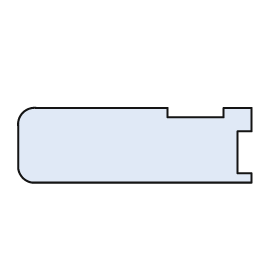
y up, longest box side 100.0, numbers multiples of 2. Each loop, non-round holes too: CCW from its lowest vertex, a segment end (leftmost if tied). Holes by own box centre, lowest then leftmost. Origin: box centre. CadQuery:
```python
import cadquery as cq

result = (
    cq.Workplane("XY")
    .moveTo(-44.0, -16.0)
    .lineTo(50.0, -16.0)
    .lineTo(50.0, -12.0)
    .lineTo(44.0, -12.0)
    .lineTo(44.0, 6.0)
    .lineTo(50.0, 6.0)
    .lineTo(50.0, 16.0)
    .lineTo(38.0, 16.0)
    .lineTo(38.0, 12.0)
    .lineTo(14.0, 12.0)
    .lineTo(14.0, 16.0)
    .lineTo(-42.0, 16.0)
    .threePointArc((-48.0, 14.0), (-50.0, 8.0))
    .lineTo(-50.0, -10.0)
    .threePointArc((-48.0, -14.0), (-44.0, -16.0))
    .close()
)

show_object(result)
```